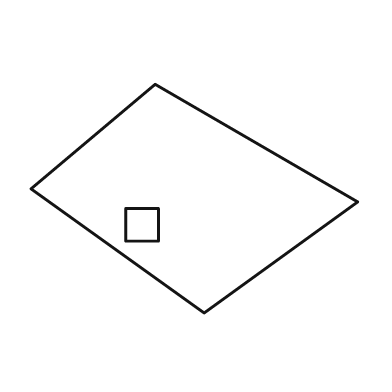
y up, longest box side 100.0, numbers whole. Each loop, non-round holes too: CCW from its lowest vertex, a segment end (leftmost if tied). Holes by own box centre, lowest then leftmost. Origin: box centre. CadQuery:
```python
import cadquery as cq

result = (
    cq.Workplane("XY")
    .moveTo(3.0, -35.0)
    .lineTo(50.0, -1.0)
    .lineTo(-12.0, 35.0)
    .lineTo(-50.0, 3.0)
    .close()
    .moveTo(-21.0, -13.0)
    .lineTo(-11.0, -13.0)
    .lineTo(-11.0, -3.0)
    .lineTo(-21.0, -3.0)
    .close()
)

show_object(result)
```